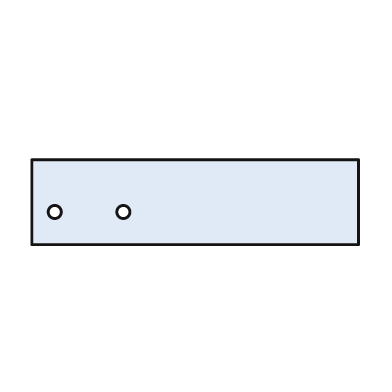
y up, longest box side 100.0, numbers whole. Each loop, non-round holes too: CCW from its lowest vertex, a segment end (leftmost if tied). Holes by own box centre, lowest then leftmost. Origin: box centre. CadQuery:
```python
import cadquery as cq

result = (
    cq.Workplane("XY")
    .moveTo(-50.0, -13.0)
    .lineTo(50.0, -13.0)
    .lineTo(50.0, 13.0)
    .lineTo(-50.0, 13.0)
    .close()
    .moveTo(-43.0, -3.0)
    .circle(2.0)
    .moveTo(-22.0, -3.0)
    .circle(2.0)
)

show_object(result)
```